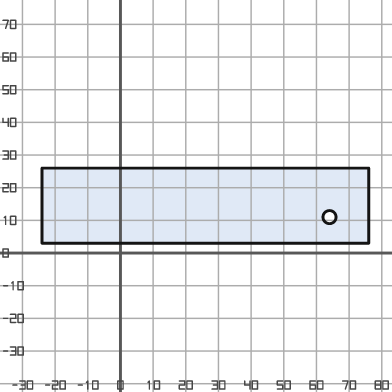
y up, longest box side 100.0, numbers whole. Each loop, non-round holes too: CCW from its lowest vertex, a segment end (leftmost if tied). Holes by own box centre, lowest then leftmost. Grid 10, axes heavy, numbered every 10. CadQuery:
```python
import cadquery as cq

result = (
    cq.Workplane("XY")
    .moveTo(-24.0, 3.0)
    .lineTo(76.0, 3.0)
    .lineTo(76.0, 26.0)
    .lineTo(-24.0, 26.0)
    .close()
    .moveTo(64.0, 11.0)
    .circle(2.0)
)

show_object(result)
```